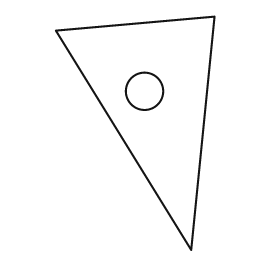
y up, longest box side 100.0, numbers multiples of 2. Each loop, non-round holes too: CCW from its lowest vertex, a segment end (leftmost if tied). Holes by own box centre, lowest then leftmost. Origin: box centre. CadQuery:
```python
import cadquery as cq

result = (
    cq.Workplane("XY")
    .moveTo(24.0, -50.0)
    .lineTo(34.0, 50.0)
    .lineTo(-34.0, 44.0)
    .close()
    .moveTo(4.0, 18.0)
    .circle(8.0)
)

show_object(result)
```